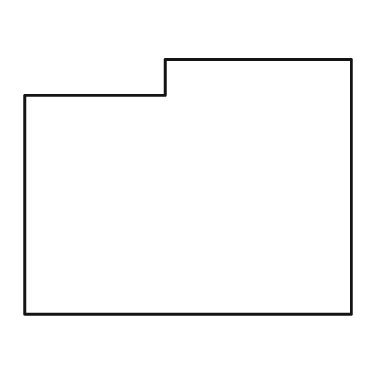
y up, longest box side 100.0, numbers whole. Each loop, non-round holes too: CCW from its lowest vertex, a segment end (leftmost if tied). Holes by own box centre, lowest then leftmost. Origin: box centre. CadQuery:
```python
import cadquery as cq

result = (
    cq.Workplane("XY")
    .moveTo(-50.0, -39.0)
    .lineTo(50.0, -39.0)
    .lineTo(50.0, 39.0)
    .lineTo(-7.0, 39.0)
    .lineTo(-7.0, 28.0)
    .lineTo(-50.0, 28.0)
    .close()
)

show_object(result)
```